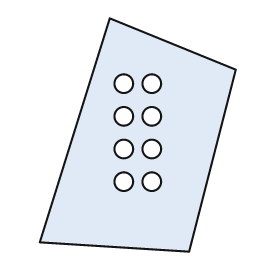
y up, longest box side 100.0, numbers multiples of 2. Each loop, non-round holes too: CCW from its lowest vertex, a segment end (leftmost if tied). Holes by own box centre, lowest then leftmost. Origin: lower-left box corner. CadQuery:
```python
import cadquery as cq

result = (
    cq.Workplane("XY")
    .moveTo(64.0, 0.0)
    .lineTo(84.0, 78.0)
    .lineTo(30.0, 100.0)
    .lineTo(0.0, 4.0)
    .close()
    .moveTo(36.0, 30.0)
    .circle(4.0)
    .moveTo(48.0, 30.0)
    .circle(4.0)
    .moveTo(36.0, 44.0)
    .circle(4.0)
    .moveTo(48.0, 44.0)
    .circle(4.0)
    .moveTo(36.0, 58.0)
    .circle(4.0)
    .moveTo(48.0, 58.0)
    .circle(4.0)
    .moveTo(36.0, 72.0)
    .circle(4.0)
    .moveTo(48.0, 72.0)
    .circle(4.0)
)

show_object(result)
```